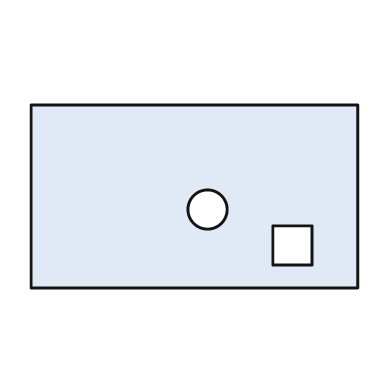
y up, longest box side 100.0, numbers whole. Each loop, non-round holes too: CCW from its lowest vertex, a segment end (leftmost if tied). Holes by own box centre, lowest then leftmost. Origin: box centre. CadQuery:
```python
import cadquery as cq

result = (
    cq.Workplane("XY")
    .moveTo(-50.0, -28.0)
    .lineTo(50.0, -28.0)
    .lineTo(50.0, 28.0)
    .lineTo(-50.0, 28.0)
    .close()
    .moveTo(24.0, -21.0)
    .lineTo(36.0, -21.0)
    .lineTo(36.0, -9.0)
    .lineTo(24.0, -9.0)
    .close()
    .moveTo(4.0, -4.0)
    .circle(6.0)
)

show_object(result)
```